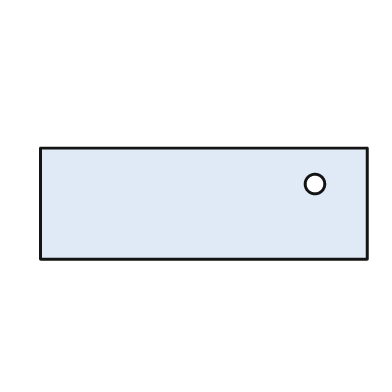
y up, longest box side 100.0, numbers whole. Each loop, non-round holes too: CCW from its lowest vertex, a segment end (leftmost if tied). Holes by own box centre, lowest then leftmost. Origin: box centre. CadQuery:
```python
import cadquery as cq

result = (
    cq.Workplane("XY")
    .moveTo(-50.0, -17.0)
    .lineTo(50.0, -17.0)
    .lineTo(50.0, 17.0)
    .lineTo(-50.0, 17.0)
    .close()
    .moveTo(34.0, 6.0)
    .circle(3.0)
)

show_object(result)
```